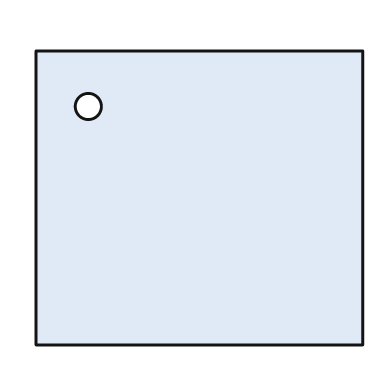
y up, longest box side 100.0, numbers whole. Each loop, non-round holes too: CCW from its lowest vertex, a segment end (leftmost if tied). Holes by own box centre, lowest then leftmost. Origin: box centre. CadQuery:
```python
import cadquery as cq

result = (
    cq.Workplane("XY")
    .moveTo(-50.0, -45.0)
    .lineTo(50.0, -45.0)
    .lineTo(50.0, 45.0)
    .lineTo(-50.0, 45.0)
    .close()
    .moveTo(-34.0, 28.0)
    .circle(4.0)
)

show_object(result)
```